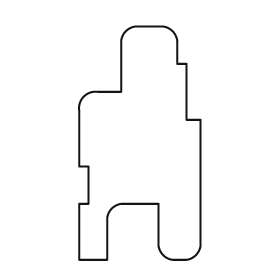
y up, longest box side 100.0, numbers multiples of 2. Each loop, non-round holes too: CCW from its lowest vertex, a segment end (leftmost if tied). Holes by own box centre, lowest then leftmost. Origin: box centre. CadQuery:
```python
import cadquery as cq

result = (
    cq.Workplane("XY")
    .moveTo(-26.0, -50.0)
    .lineTo(-14.0, -50.0)
    .lineTo(-14.0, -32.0)
    .threePointArc((-12.0, -28.0), (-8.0, -26.0))
    .lineTo(8.0, -26.0)
    .lineTo(8.0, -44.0)
    .threePointArc((10.0, -48.0), (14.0, -50.0))
    .lineTo(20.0, -50.0)
    .threePointArc((24.0, -48.0), (26.0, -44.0))
    .lineTo(26.0, 10.0)
    .lineTo(20.0, 10.0)
    .lineTo(20.0, 34.0)
    .lineTo(16.0, 34.0)
    .lineTo(16.0, 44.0)
    .threePointArc((14.0, 48.0), (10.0, 50.0))
    .lineTo(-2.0, 50.0)
    .threePointArc((-6.0, 48.0), (-8.0, 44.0))
    .lineTo(-8.0, 22.0)
    .lineTo(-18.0, 22.0)
    .threePointArc((-24.0, 20.0), (-26.0, 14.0))
    .lineTo(-26.0, -10.0)
    .lineTo(-22.0, -10.0)
    .lineTo(-22.0, -26.0)
    .lineTo(-26.0, -26.0)
    .close()
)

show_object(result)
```